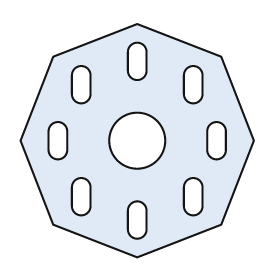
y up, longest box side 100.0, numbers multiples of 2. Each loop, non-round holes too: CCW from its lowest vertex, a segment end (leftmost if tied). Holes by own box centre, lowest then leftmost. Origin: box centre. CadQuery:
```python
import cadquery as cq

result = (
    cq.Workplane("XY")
    .moveTo(0.0, -50.0)
    .lineTo(36.0, -36.0)
    .lineTo(50.0, 0.0)
    .lineTo(36.0, 36.0)
    .lineTo(0.0, 50.0)
    .lineTo(-36.0, 36.0)
    .lineTo(-50.0, 0.0)
    .lineTo(-36.0, -36.0)
    .close()
    .moveTo(-4.0, -38.0)
    .threePointArc((0.0, -42.0), (4.0, -38.0))
    .lineTo(4.0, -30.0)
    .threePointArc((0.0, -26.0), (-4.0, -30.0))
    .close()
    .moveTo(-28.0, -28.0)
    .threePointArc((-24.0, -32.0), (-20.0, -28.0))
    .lineTo(-20.0, -20.0)
    .threePointArc((-24.0, -16.0), (-28.0, -20.0))
    .close()
    .moveTo(20.0, -28.0)
    .threePointArc((24.0, -32.0), (28.0, -28.0))
    .lineTo(28.0, -20.0)
    .threePointArc((24.0, -16.0), (20.0, -20.0))
    .close()
    .moveTo(-38.0, -4.0)
    .threePointArc((-34.0, -8.0), (-30.0, -4.0))
    .lineTo(-30.0, 4.0)
    .threePointArc((-34.0, 8.0), (-38.0, 4.0))
    .close()
    .moveTo(0.0, 0.0)
    .circle(12.0)
    .moveTo(30.0, -4.0)
    .threePointArc((34.0, -8.0), (38.0, -4.0))
    .lineTo(38.0, 4.0)
    .threePointArc((34.0, 8.0), (30.0, 4.0))
    .close()
    .moveTo(-28.0, 20.0)
    .threePointArc((-24.0, 16.0), (-20.0, 20.0))
    .lineTo(-20.0, 28.0)
    .threePointArc((-24.0, 32.0), (-28.0, 28.0))
    .close()
    .moveTo(20.0, 20.0)
    .threePointArc((24.0, 16.0), (28.0, 20.0))
    .lineTo(28.0, 28.0)
    .threePointArc((24.0, 32.0), (20.0, 28.0))
    .close()
    .moveTo(-4.0, 30.0)
    .threePointArc((0.0, 26.0), (4.0, 30.0))
    .lineTo(4.0, 38.0)
    .threePointArc((0.0, 42.0), (-4.0, 38.0))
    .close()
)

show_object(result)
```